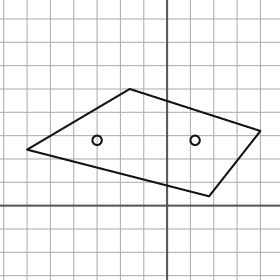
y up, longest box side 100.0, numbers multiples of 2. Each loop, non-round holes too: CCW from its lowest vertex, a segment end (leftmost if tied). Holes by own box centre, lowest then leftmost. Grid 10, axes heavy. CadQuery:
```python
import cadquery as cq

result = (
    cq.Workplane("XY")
    .moveTo(18.0, 4.0)
    .lineTo(40.0, 32.0)
    .lineTo(-16.0, 50.0)
    .lineTo(-60.0, 24.0)
    .close()
    .moveTo(-30.0, 28.0)
    .circle(2.0)
    .moveTo(12.0, 28.0)
    .circle(2.0)
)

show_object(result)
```